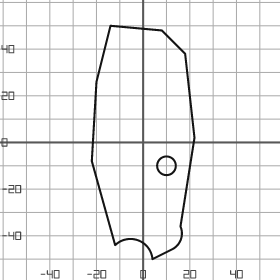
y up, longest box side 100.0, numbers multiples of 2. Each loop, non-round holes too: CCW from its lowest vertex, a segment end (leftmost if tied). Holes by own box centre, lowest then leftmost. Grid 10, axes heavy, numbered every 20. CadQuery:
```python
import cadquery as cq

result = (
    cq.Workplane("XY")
    .moveTo(4.0, -50.0)
    .lineTo(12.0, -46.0)
    .threePointArc((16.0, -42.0), (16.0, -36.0))
    .lineTo(22.0, 2.0)
    .lineTo(18.0, 38.0)
    .lineTo(8.0, 48.0)
    .lineTo(-14.0, 50.0)
    .lineTo(-20.0, 26.0)
    .lineTo(-22.0, -8.0)
    .lineTo(-12.0, -44.0)
    .threePointArc((-2.0, -42.0), (4.0, -50.0))
    .close()
    .moveTo(10.0, -10.0)
    .circle(4.0)
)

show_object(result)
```